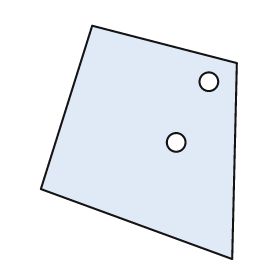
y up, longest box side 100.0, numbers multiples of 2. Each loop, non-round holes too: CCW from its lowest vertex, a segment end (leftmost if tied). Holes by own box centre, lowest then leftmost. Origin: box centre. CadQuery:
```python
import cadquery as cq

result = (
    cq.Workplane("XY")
    .moveTo(40.0, -50.0)
    .lineTo(42.0, 34.0)
    .lineTo(-20.0, 50.0)
    .lineTo(-42.0, -20.0)
    .close()
    .moveTo(16.0, 0.0)
    .circle(4.0)
    .moveTo(30.0, 26.0)
    .circle(4.0)
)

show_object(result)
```